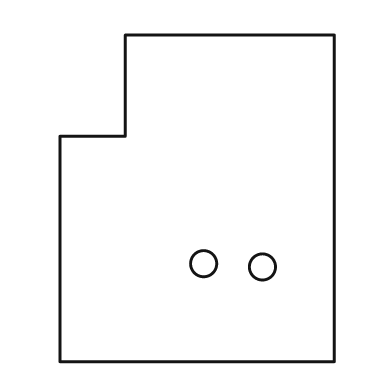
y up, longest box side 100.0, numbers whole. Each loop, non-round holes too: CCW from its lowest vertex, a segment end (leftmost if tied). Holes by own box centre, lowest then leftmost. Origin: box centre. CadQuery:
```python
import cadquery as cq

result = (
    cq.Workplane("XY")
    .moveTo(-42.0, -50.0)
    .lineTo(42.0, -50.0)
    .lineTo(42.0, 50.0)
    .lineTo(-22.0, 50.0)
    .lineTo(-22.0, 19.0)
    .lineTo(-42.0, 19.0)
    .close()
    .moveTo(20.0, -21.0)
    .circle(4.0)
    .moveTo(2.0, -20.0)
    .circle(4.0)
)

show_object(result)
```